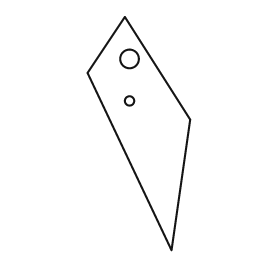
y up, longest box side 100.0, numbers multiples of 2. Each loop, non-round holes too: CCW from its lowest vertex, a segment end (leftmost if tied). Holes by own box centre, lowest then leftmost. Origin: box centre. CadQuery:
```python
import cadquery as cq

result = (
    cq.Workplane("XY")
    .moveTo(14.0, -50.0)
    .lineTo(22.0, 6.0)
    .lineTo(-6.0, 50.0)
    .lineTo(-22.0, 26.0)
    .close()
    .moveTo(-4.0, 14.0)
    .circle(2.0)
    .moveTo(-4.0, 32.0)
    .circle(4.0)
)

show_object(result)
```